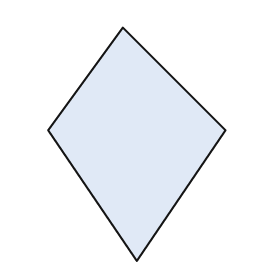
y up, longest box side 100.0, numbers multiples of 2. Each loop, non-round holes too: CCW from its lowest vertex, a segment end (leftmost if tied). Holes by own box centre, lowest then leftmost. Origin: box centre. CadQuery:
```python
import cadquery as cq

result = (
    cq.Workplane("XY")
    .moveTo(0.0, -50.0)
    .lineTo(38.0, 6.0)
    .lineTo(-6.0, 50.0)
    .lineTo(-38.0, 6.0)
    .close()
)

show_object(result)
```